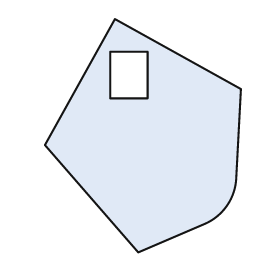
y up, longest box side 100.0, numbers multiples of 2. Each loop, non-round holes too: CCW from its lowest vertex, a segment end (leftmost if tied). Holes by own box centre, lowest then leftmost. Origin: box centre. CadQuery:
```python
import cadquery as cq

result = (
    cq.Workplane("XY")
    .moveTo(-2.0, -50.0)
    .lineTo(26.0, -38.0)
    .threePointArc((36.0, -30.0), (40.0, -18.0))
    .lineTo(42.0, 20.0)
    .lineTo(-12.0, 50.0)
    .lineTo(-42.0, -4.0)
    .close()
    .moveTo(-14.0, 16.0)
    .lineTo(2.0, 16.0)
    .lineTo(2.0, 36.0)
    .lineTo(-14.0, 36.0)
    .close()
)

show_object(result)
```